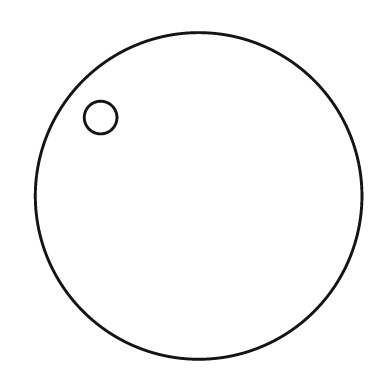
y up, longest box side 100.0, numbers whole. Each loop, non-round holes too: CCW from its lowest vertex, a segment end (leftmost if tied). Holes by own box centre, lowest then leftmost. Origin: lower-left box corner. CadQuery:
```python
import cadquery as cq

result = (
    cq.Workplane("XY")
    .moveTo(50.0, 50.0)
    .circle(50.0)
    .moveTo(20.0, 74.0)
    .circle(5.0)
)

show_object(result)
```